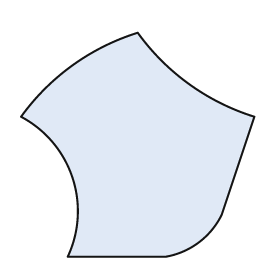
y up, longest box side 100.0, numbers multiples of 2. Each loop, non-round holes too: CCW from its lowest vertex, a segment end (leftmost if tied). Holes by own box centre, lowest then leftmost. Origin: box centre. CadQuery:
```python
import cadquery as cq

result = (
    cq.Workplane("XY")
    .moveTo(-30.0, -48.0)
    .lineTo(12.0, -48.0)
    .threePointArc((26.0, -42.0), (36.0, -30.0))
    .lineTo(50.0, 12.0)
    .threePointArc((22.0, 26.0), (0.0, 48.0))
    .threePointArc((-28.0, 34.0), (-50.0, 12.0))
    .threePointArc((-28.0, -14.0), (-30.0, -48.0))
    .close()
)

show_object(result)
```